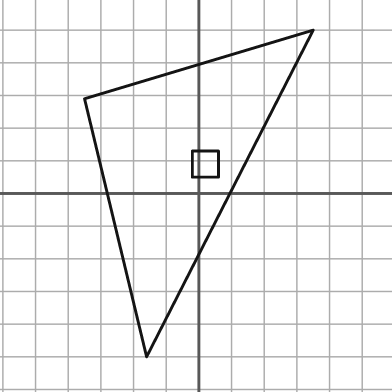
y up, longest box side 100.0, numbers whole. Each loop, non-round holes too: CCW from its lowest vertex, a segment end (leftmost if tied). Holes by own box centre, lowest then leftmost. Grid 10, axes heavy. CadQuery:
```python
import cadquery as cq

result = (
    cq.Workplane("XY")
    .moveTo(-16.0, -50.0)
    .lineTo(35.0, 50.0)
    .lineTo(-35.0, 29.0)
    .close()
    .moveTo(-2.0, 5.0)
    .lineTo(6.0, 5.0)
    .lineTo(6.0, 13.0)
    .lineTo(-2.0, 13.0)
    .close()
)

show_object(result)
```